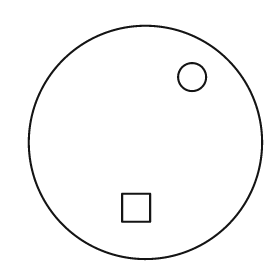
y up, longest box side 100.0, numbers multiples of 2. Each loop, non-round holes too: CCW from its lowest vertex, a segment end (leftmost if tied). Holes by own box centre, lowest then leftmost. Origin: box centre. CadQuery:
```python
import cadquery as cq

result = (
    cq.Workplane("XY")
    .moveTo(0.0, 0.0)
    .circle(50.0)
    .moveTo(-10.0, -34.0)
    .lineTo(2.0, -34.0)
    .lineTo(2.0, -22.0)
    .lineTo(-10.0, -22.0)
    .close()
    .moveTo(20.0, 28.0)
    .circle(6.0)
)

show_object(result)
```